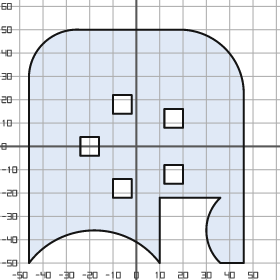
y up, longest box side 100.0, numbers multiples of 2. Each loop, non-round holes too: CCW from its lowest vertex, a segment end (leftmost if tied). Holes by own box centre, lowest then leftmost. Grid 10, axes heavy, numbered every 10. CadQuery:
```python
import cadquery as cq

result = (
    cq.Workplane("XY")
    .moveTo(-46.0, -50.0)
    .threePointArc((-18.0, -36.0), (10.0, -50.0))
    .lineTo(10.0, -22.0)
    .lineTo(36.0, -22.0)
    .threePointArc((30.0, -36.0), (36.0, -50.0))
    .lineTo(46.0, -50.0)
    .lineTo(46.0, 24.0)
    .threePointArc((38.0, 42.0), (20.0, 50.0))
    .lineTo(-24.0, 50.0)
    .threePointArc((-40.0, 44.0), (-46.0, 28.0))
    .close()
    .moveTo(-10.0, -22.0)
    .lineTo(-2.0, -22.0)
    .lineTo(-2.0, -14.0)
    .lineTo(-10.0, -14.0)
    .close()
    .moveTo(12.0, -16.0)
    .lineTo(20.0, -16.0)
    .lineTo(20.0, -8.0)
    .lineTo(12.0, -8.0)
    .close()
    .moveTo(-24.0, -4.0)
    .lineTo(-16.0, -4.0)
    .lineTo(-16.0, 4.0)
    .lineTo(-24.0, 4.0)
    .close()
    .moveTo(12.0, 8.0)
    .lineTo(20.0, 8.0)
    .lineTo(20.0, 16.0)
    .lineTo(12.0, 16.0)
    .close()
    .moveTo(-10.0, 14.0)
    .lineTo(-2.0, 14.0)
    .lineTo(-2.0, 22.0)
    .lineTo(-10.0, 22.0)
    .close()
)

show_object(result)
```